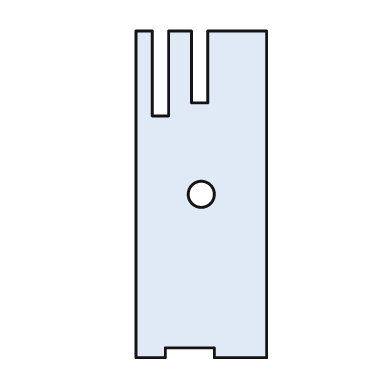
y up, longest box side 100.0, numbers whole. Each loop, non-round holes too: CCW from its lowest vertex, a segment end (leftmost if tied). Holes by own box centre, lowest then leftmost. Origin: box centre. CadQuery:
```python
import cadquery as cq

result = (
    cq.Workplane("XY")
    .moveTo(-20.0, -50.0)
    .lineTo(-11.0, -50.0)
    .lineTo(-11.0, -47.0)
    .lineTo(4.0, -47.0)
    .lineTo(4.0, -50.0)
    .lineTo(20.0, -50.0)
    .lineTo(20.0, 50.0)
    .lineTo(2.0, 50.0)
    .lineTo(2.0, 28.0)
    .lineTo(-3.0, 28.0)
    .lineTo(-3.0, 50.0)
    .lineTo(-10.0, 50.0)
    .lineTo(-10.0, 24.0)
    .lineTo(-15.0, 24.0)
    .lineTo(-15.0, 50.0)
    .lineTo(-20.0, 50.0)
    .close()
    .moveTo(0.0, 0.0)
    .circle(4.0)
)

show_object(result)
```